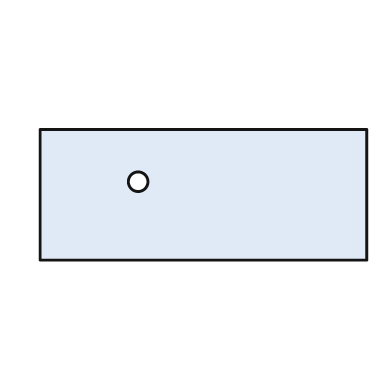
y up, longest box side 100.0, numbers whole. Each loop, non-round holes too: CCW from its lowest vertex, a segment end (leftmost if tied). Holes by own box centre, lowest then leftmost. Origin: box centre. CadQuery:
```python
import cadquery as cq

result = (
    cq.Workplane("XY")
    .moveTo(-50.0, -20.0)
    .lineTo(50.0, -20.0)
    .lineTo(50.0, 20.0)
    .lineTo(-50.0, 20.0)
    .close()
    .moveTo(-20.0, 4.0)
    .circle(3.0)
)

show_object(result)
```